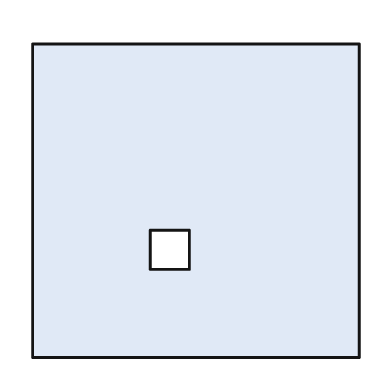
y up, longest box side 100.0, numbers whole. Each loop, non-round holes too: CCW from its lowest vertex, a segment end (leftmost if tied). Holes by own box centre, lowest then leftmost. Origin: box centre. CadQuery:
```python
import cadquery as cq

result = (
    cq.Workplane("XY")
    .moveTo(-50.0, -48.0)
    .lineTo(50.0, -48.0)
    .lineTo(50.0, 48.0)
    .lineTo(-50.0, 48.0)
    .close()
    .moveTo(-14.0, -21.0)
    .lineTo(-2.0, -21.0)
    .lineTo(-2.0, -9.0)
    .lineTo(-14.0, -9.0)
    .close()
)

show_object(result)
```